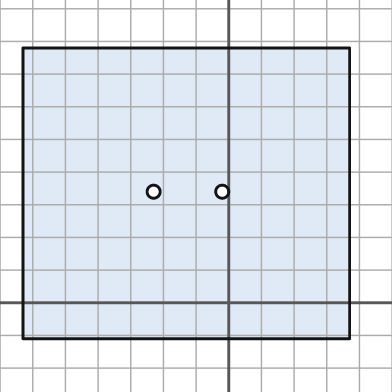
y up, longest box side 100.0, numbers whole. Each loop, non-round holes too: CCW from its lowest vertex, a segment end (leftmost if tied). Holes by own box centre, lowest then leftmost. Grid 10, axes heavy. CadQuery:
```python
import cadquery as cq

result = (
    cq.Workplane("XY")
    .moveTo(-63.0, -11.0)
    .lineTo(37.0, -11.0)
    .lineTo(37.0, 78.0)
    .lineTo(-63.0, 78.0)
    .close()
    .moveTo(-23.0, 34.0)
    .circle(2.0)
    .moveTo(-2.0, 34.0)
    .circle(2.0)
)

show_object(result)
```